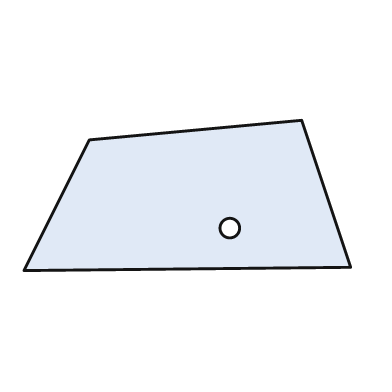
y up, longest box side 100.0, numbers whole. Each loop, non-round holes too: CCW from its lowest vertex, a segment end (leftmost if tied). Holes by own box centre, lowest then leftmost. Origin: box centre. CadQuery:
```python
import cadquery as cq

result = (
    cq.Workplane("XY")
    .moveTo(-50.0, -23.0)
    .lineTo(50.0, -22.0)
    .lineTo(35.0, 23.0)
    .lineTo(-30.0, 17.0)
    .close()
    .moveTo(13.0, -10.0)
    .circle(3.0)
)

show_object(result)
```